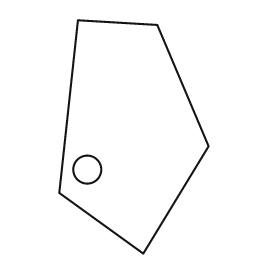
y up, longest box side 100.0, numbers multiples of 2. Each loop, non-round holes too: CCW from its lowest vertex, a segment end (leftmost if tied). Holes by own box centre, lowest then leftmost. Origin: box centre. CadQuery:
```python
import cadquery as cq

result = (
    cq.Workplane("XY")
    .moveTo(4.0, -50.0)
    .lineTo(32.0, -4.0)
    .lineTo(10.0, 48.0)
    .lineTo(-24.0, 50.0)
    .lineTo(-32.0, -24.0)
    .close()
    .moveTo(-20.0, -14.0)
    .circle(6.0)
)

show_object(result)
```